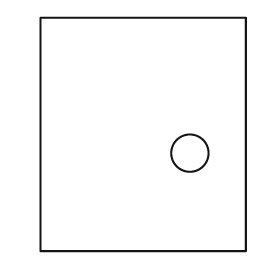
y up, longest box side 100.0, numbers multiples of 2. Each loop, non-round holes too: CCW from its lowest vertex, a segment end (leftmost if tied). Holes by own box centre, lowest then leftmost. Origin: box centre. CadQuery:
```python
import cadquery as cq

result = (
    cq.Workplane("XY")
    .moveTo(-44.0, -50.0)
    .lineTo(44.0, -50.0)
    .lineTo(44.0, 50.0)
    .lineTo(-44.0, 50.0)
    .close()
    .moveTo(20.0, -8.0)
    .circle(8.0)
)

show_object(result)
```